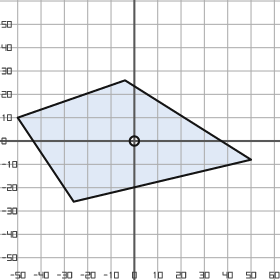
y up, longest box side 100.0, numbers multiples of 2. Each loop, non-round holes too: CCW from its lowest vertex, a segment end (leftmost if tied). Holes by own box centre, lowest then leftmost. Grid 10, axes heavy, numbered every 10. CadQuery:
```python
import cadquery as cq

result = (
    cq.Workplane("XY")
    .moveTo(-26.0, -26.0)
    .lineTo(50.0, -8.0)
    .lineTo(-4.0, 26.0)
    .lineTo(-50.0, 10.0)
    .close()
    .moveTo(0.0, 0.0)
    .circle(2.0)
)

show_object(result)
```